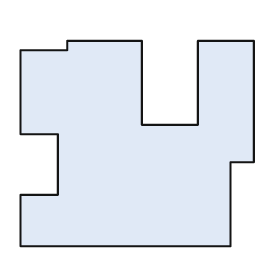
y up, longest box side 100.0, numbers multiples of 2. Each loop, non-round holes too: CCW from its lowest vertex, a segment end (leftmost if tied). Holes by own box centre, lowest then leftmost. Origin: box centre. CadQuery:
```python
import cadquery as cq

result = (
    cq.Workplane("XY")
    .moveTo(-50.0, -44.0)
    .lineTo(40.0, -44.0)
    .lineTo(40.0, -8.0)
    .lineTo(50.0, -8.0)
    .lineTo(50.0, 44.0)
    .lineTo(26.0, 44.0)
    .lineTo(26.0, 8.0)
    .lineTo(2.0, 8.0)
    .lineTo(2.0, 44.0)
    .lineTo(-30.0, 44.0)
    .lineTo(-30.0, 40.0)
    .lineTo(-50.0, 40.0)
    .lineTo(-50.0, 4.0)
    .lineTo(-34.0, 4.0)
    .lineTo(-34.0, -22.0)
    .lineTo(-50.0, -22.0)
    .close()
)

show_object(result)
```